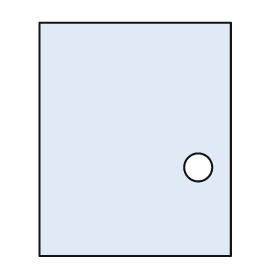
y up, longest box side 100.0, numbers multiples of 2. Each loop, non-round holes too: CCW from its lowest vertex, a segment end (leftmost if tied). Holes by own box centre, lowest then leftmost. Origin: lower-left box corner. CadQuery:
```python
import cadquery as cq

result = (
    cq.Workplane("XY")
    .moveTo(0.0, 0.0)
    .lineTo(82.0, 0.0)
    .lineTo(82.0, 100.0)
    .lineTo(0.0, 100.0)
    .close()
    .moveTo(68.0, 38.0)
    .circle(6.0)
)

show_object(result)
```